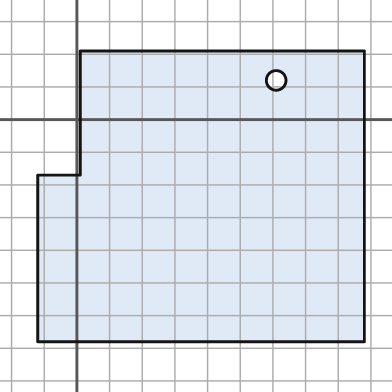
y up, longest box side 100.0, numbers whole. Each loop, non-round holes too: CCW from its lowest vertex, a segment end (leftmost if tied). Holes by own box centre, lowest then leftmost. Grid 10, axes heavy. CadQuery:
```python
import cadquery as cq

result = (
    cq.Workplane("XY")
    .moveTo(-12.0, -68.0)
    .lineTo(88.0, -68.0)
    .lineTo(88.0, 21.0)
    .lineTo(1.0, 21.0)
    .lineTo(1.0, -17.0)
    .lineTo(-12.0, -17.0)
    .close()
    .moveTo(61.0, 12.0)
    .circle(3.0)
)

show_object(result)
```